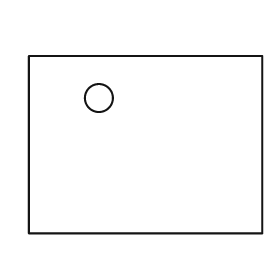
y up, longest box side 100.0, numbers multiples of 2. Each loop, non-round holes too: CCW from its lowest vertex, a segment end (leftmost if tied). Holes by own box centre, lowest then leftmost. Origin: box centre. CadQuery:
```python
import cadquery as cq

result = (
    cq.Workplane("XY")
    .moveTo(-50.0, -38.0)
    .lineTo(50.0, -38.0)
    .lineTo(50.0, 38.0)
    .lineTo(-50.0, 38.0)
    .close()
    .moveTo(-20.0, 20.0)
    .circle(6.0)
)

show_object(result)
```